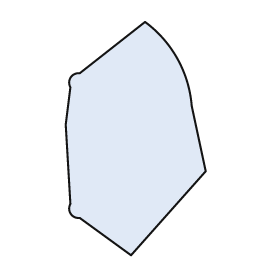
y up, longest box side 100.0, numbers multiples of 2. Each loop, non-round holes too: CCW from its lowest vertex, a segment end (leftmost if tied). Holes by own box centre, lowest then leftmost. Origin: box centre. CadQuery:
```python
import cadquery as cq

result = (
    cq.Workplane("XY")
    .moveTo(-2.0, -50.0)
    .lineTo(30.0, -14.0)
    .lineTo(24.0, 14.0)
    .threePointArc((18.0, 34.0), (4.0, 50.0))
    .lineTo(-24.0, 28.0)
    .threePointArc((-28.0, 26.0), (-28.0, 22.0))
    .lineTo(-30.0, 6.0)
    .lineTo(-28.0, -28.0)
    .threePointArc((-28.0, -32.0), (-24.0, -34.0))
    .close()
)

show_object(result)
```